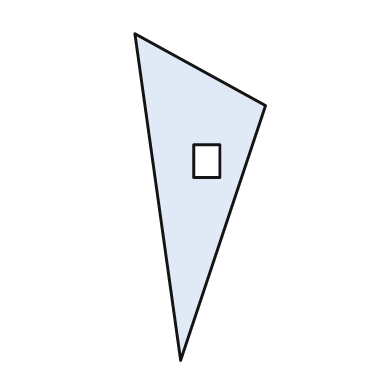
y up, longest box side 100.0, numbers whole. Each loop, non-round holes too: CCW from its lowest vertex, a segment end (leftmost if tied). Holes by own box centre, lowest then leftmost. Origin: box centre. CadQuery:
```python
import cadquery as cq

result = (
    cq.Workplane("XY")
    .moveTo(-6.0, -50.0)
    .lineTo(20.0, 28.0)
    .lineTo(-20.0, 50.0)
    .close()
    .moveTo(-2.0, 6.0)
    .lineTo(6.0, 6.0)
    .lineTo(6.0, 16.0)
    .lineTo(-2.0, 16.0)
    .close()
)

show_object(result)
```